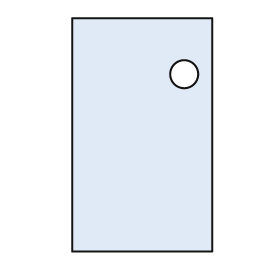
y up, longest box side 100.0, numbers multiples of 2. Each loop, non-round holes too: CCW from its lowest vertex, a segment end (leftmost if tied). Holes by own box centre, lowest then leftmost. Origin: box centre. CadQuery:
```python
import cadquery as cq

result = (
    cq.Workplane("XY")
    .moveTo(-30.0, -50.0)
    .lineTo(30.0, -50.0)
    .lineTo(30.0, 50.0)
    .lineTo(-30.0, 50.0)
    .close()
    .moveTo(18.0, 26.0)
    .circle(6.0)
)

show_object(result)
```